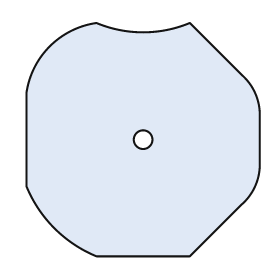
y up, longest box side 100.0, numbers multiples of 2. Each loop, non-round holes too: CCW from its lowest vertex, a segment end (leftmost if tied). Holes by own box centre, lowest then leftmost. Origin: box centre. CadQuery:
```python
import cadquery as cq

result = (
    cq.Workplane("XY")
    .moveTo(-20.0, -50.0)
    .lineTo(20.0, -50.0)
    .lineTo(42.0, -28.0)
    .threePointArc((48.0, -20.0), (50.0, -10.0))
    .lineTo(50.0, 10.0)
    .threePointArc((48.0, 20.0), (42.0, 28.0))
    .lineTo(20.0, 50.0)
    .threePointArc((0.0, 46.0), (-20.0, 50.0))
    .threePointArc((-40.0, 40.0), (-50.0, 20.0))
    .lineTo(-50.0, -20.0)
    .threePointArc((-38.0, -38.0), (-20.0, -50.0))
    .close()
    .moveTo(0.0, 0.0)
    .circle(4.0)
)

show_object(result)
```